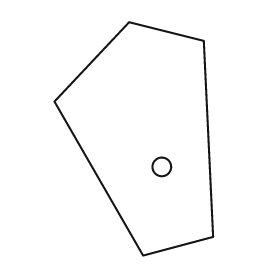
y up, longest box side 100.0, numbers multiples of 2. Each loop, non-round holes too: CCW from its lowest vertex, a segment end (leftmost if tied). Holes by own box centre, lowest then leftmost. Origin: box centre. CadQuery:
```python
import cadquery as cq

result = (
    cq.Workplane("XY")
    .moveTo(4.0, -50.0)
    .lineTo(34.0, -42.0)
    .lineTo(30.0, 42.0)
    .lineTo(-2.0, 50.0)
    .lineTo(-34.0, 16.0)
    .close()
    .moveTo(12.0, -12.0)
    .circle(4.0)
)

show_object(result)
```